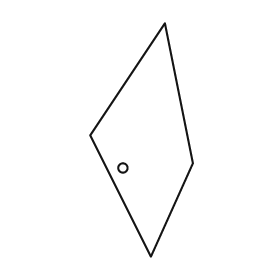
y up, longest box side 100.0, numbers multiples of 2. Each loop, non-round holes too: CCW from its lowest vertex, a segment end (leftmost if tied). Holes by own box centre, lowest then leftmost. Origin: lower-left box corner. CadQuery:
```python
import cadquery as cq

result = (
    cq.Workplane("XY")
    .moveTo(26.0, 0.0)
    .lineTo(44.0, 40.0)
    .lineTo(32.0, 100.0)
    .lineTo(0.0, 52.0)
    .close()
    .moveTo(14.0, 38.0)
    .circle(2.0)
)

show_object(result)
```